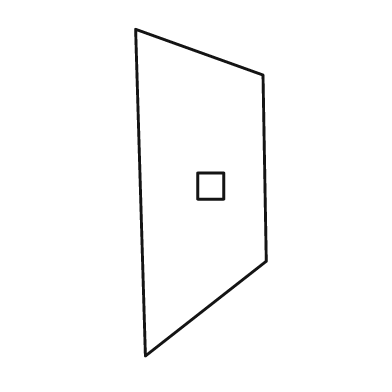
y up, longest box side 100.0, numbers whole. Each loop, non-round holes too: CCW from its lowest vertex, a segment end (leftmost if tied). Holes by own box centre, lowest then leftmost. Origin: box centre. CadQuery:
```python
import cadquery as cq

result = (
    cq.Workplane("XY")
    .moveTo(-17.0, -50.0)
    .lineTo(20.0, -21.0)
    .lineTo(19.0, 36.0)
    .lineTo(-20.0, 50.0)
    .close()
    .moveTo(-1.0, -2.0)
    .lineTo(7.0, -2.0)
    .lineTo(7.0, 6.0)
    .lineTo(-1.0, 6.0)
    .close()
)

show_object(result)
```